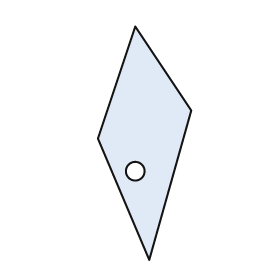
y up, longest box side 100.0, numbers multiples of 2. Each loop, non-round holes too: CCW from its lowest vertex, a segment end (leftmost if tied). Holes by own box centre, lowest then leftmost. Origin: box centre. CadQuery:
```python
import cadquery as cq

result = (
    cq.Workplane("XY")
    .moveTo(2.0, -50.0)
    .lineTo(20.0, 14.0)
    .lineTo(-4.0, 50.0)
    .lineTo(-20.0, 2.0)
    .close()
    .moveTo(-4.0, -12.0)
    .circle(4.0)
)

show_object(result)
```